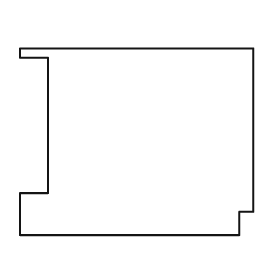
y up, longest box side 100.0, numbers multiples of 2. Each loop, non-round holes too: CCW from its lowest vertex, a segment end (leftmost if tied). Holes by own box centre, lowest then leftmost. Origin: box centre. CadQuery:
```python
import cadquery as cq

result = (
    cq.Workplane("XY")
    .moveTo(-50.0, -40.0)
    .lineTo(44.0, -40.0)
    .lineTo(44.0, -30.0)
    .lineTo(50.0, -30.0)
    .lineTo(50.0, 40.0)
    .lineTo(-50.0, 40.0)
    .lineTo(-50.0, 36.0)
    .lineTo(-38.0, 36.0)
    .lineTo(-38.0, -22.0)
    .lineTo(-50.0, -22.0)
    .close()
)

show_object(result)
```